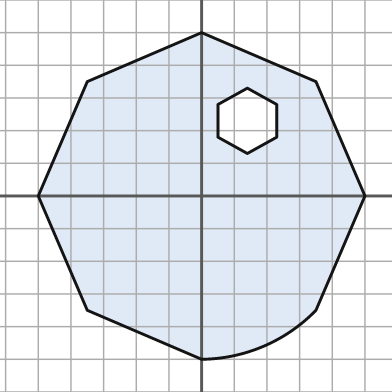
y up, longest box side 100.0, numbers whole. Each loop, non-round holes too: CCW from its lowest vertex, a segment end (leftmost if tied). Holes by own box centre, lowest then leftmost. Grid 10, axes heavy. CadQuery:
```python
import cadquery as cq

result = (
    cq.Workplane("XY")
    .moveTo(0.0, -50.0)
    .threePointArc((19.0, -46.0), (35.0, -35.0))
    .lineTo(50.0, 0.0)
    .lineTo(35.0, 35.0)
    .lineTo(0.0, 50.0)
    .lineTo(-35.0, 35.0)
    .lineTo(-50.0, 0.0)
    .lineTo(-35.0, -35.0)
    .close()
    .moveTo(14.0, 13.0)
    .lineTo(23.0, 18.0)
    .lineTo(23.0, 28.0)
    .lineTo(14.0, 33.0)
    .lineTo(5.0, 28.0)
    .lineTo(5.0, 18.0)
    .close()
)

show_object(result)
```